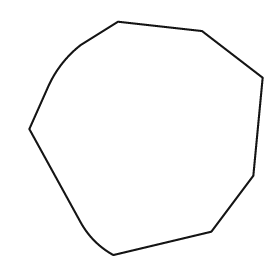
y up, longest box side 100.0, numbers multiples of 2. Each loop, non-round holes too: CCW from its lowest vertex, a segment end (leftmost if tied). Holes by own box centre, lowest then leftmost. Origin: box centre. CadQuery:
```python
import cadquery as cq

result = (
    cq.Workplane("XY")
    .moveTo(-14.0, -50.0)
    .lineTo(28.0, -40.0)
    .lineTo(46.0, -16.0)
    .lineTo(50.0, 26.0)
    .lineTo(24.0, 46.0)
    .lineTo(-12.0, 50.0)
    .lineTo(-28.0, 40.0)
    .threePointArc((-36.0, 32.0), (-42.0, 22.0))
    .lineTo(-50.0, 4.0)
    .lineTo(-28.0, -36.0)
    .threePointArc((-22.0, -44.0), (-14.0, -50.0))
    .close()
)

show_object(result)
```